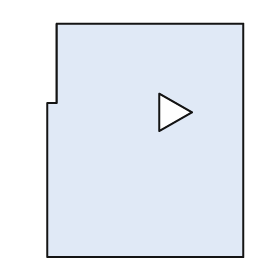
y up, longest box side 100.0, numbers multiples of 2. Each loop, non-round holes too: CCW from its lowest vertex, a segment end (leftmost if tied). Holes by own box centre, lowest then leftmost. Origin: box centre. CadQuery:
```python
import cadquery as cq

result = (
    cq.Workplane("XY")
    .moveTo(-42.0, -50.0)
    .lineTo(42.0, -50.0)
    .lineTo(42.0, 50.0)
    .lineTo(-38.0, 50.0)
    .lineTo(-38.0, 16.0)
    .lineTo(-42.0, 16.0)
    .close()
    .moveTo(6.0, 4.0)
    .lineTo(20.0, 12.0)
    .lineTo(6.0, 20.0)
    .close()
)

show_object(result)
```